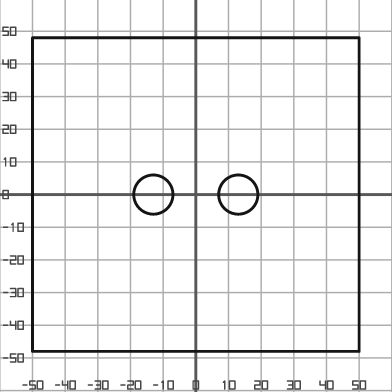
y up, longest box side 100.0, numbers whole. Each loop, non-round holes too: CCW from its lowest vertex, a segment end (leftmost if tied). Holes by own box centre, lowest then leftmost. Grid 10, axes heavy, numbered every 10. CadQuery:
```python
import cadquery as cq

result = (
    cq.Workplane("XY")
    .moveTo(-50.0, -48.0)
    .lineTo(50.0, -48.0)
    .lineTo(50.0, 48.0)
    .lineTo(-50.0, 48.0)
    .close()
    .moveTo(-13.0, 0.0)
    .circle(6.0)
    .moveTo(13.0, 0.0)
    .circle(6.0)
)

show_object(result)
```